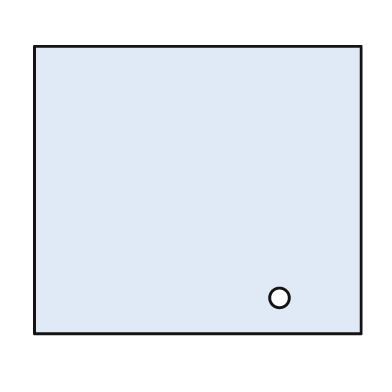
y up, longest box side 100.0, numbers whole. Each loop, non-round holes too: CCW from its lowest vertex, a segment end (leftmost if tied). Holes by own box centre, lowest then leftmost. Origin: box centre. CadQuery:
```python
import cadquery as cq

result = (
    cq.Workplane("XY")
    .moveTo(-50.0, -44.0)
    .lineTo(50.0, -44.0)
    .lineTo(50.0, 44.0)
    .lineTo(-50.0, 44.0)
    .close()
    .moveTo(25.0, -33.0)
    .circle(3.0)
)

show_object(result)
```